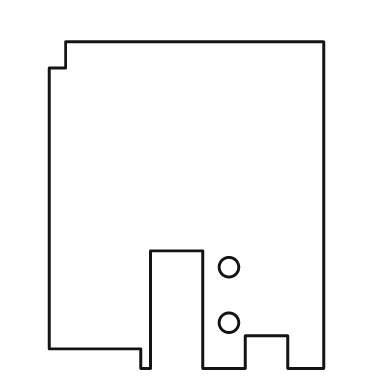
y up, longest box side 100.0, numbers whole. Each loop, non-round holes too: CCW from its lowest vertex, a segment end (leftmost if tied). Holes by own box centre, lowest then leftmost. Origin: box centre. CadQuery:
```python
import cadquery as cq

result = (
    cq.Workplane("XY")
    .moveTo(-14.0, -50.0)
    .lineTo(-11.0, -50.0)
    .lineTo(-11.0, -14.0)
    .lineTo(5.0, -14.0)
    .lineTo(5.0, -50.0)
    .lineTo(18.0, -50.0)
    .lineTo(18.0, -40.0)
    .lineTo(31.0, -40.0)
    .lineTo(31.0, -50.0)
    .lineTo(42.0, -50.0)
    .lineTo(42.0, 50.0)
    .lineTo(-37.0, 50.0)
    .lineTo(-37.0, 42.0)
    .lineTo(-42.0, 42.0)
    .lineTo(-42.0, -44.0)
    .lineTo(-14.0, -44.0)
    .close()
    .moveTo(13.0, -36.0)
    .circle(3.0)
    .moveTo(13.0, -19.0)
    .circle(3.0)
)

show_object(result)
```